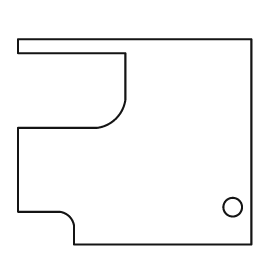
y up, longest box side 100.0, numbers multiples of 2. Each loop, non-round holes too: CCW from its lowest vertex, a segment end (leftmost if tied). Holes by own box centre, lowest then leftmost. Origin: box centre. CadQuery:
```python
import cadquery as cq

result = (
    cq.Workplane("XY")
    .moveTo(-26.0, -44.0)
    .lineTo(50.0, -44.0)
    .lineTo(50.0, 44.0)
    .lineTo(-50.0, 44.0)
    .lineTo(-50.0, 38.0)
    .lineTo(-4.0, 38.0)
    .lineTo(-4.0, 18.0)
    .threePointArc((-8.0, 10.0), (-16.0, 6.0))
    .lineTo(-50.0, 6.0)
    .lineTo(-50.0, -30.0)
    .lineTo(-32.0, -30.0)
    .threePointArc((-28.0, -32.0), (-26.0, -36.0))
    .close()
    .moveTo(42.0, -28.0)
    .circle(4.0)
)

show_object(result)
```